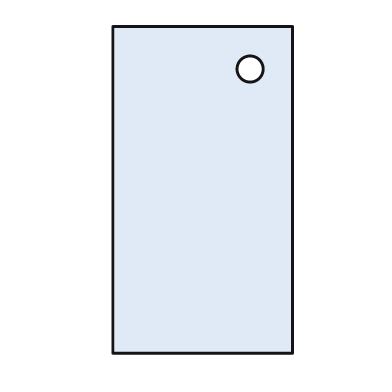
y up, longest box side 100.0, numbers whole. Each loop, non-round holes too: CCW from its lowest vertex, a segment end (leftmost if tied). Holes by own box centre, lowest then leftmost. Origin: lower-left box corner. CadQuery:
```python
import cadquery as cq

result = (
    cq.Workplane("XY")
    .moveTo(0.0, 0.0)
    .lineTo(55.0, 0.0)
    .lineTo(55.0, 100.0)
    .lineTo(0.0, 100.0)
    .close()
    .moveTo(42.0, 87.0)
    .circle(4.0)
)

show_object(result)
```